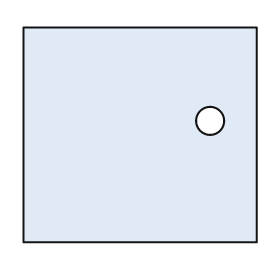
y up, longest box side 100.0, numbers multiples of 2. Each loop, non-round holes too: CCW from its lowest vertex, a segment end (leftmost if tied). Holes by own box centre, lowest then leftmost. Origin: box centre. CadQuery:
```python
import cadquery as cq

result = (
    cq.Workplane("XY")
    .moveTo(-50.0, -46.0)
    .lineTo(50.0, -46.0)
    .lineTo(50.0, 46.0)
    .lineTo(-50.0, 46.0)
    .close()
    .moveTo(30.0, 6.0)
    .circle(6.0)
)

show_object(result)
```